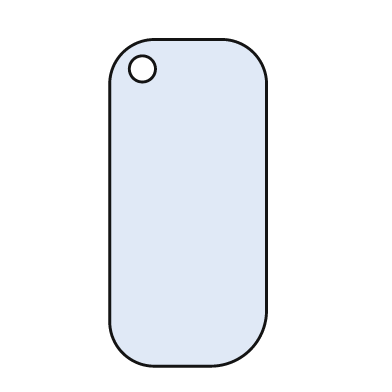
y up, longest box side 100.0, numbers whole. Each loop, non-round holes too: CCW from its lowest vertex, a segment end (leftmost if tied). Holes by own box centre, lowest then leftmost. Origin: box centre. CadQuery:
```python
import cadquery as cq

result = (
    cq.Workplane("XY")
    .moveTo(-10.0, -50.0)
    .lineTo(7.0, -50.0)
    .threePointArc((19.0, -45.0), (24.0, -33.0))
    .lineTo(24.0, 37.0)
    .threePointArc((20.0, 46.0), (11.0, 50.0))
    .lineTo(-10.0, 50.0)
    .threePointArc((-20.0, 46.0), (-24.0, 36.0))
    .lineTo(-24.0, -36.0)
    .threePointArc((-20.0, -46.0), (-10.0, -50.0))
    .close()
    .moveTo(-14.0, 41.0)
    .circle(4.0)
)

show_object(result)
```